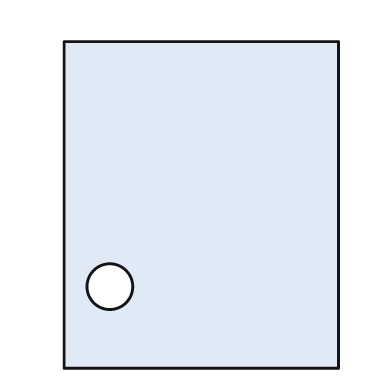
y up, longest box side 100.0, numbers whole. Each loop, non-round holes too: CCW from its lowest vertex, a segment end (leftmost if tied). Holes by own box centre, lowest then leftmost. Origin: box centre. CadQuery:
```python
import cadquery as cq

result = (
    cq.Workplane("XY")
    .moveTo(-42.0, -50.0)
    .lineTo(42.0, -50.0)
    .lineTo(42.0, 50.0)
    .lineTo(-42.0, 50.0)
    .close()
    .moveTo(-28.0, -25.0)
    .circle(7.0)
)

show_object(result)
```